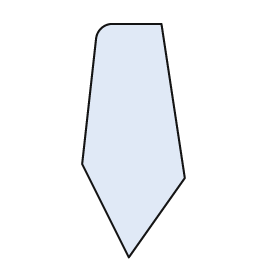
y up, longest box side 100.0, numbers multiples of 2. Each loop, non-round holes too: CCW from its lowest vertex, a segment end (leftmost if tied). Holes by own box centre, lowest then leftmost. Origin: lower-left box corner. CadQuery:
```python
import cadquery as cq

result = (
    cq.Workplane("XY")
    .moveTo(20.0, 0.0)
    .lineTo(44.0, 34.0)
    .lineTo(34.0, 100.0)
    .lineTo(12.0, 100.0)
    .threePointArc((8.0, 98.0), (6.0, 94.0))
    .lineTo(0.0, 40.0)
    .close()
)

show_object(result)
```